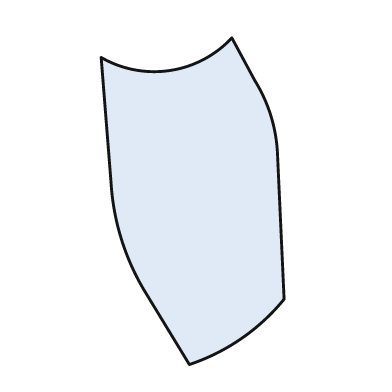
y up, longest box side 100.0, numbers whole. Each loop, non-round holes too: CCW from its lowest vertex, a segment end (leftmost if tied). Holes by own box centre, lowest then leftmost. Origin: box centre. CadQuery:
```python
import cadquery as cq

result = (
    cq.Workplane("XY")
    .moveTo(-1.0, -50.0)
    .threePointArc((15.0, -42.0), (28.0, -30.0))
    .lineTo(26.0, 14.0)
    .threePointArc((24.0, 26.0), (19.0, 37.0))
    .lineTo(12.0, 50.0)
    .threePointArc((-7.0, 40.0), (-28.0, 44.0))
    .lineTo(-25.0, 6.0)
    .threePointArc((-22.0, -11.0), (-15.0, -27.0))
    .close()
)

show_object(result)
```